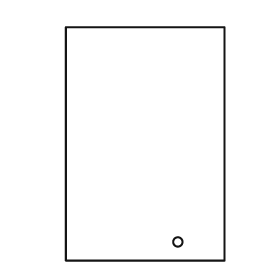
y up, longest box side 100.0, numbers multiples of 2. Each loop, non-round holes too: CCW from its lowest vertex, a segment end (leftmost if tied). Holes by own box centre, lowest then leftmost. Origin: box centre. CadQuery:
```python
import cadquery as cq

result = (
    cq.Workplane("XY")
    .moveTo(-34.0, -50.0)
    .lineTo(34.0, -50.0)
    .lineTo(34.0, 50.0)
    .lineTo(-34.0, 50.0)
    .close()
    .moveTo(14.0, -42.0)
    .circle(2.0)
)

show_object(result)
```